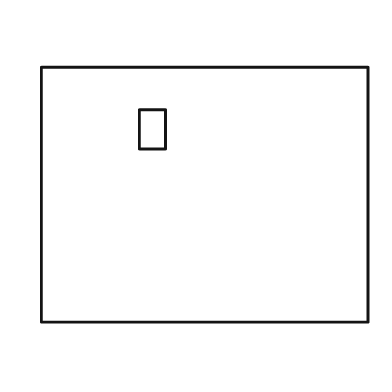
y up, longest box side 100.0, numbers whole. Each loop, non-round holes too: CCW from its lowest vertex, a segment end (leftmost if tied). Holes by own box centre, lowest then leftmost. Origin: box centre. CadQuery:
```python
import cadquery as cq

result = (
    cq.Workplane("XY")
    .moveTo(-50.0, -39.0)
    .lineTo(50.0, -39.0)
    .lineTo(50.0, 39.0)
    .lineTo(-50.0, 39.0)
    .close()
    .moveTo(-20.0, 14.0)
    .lineTo(-12.0, 14.0)
    .lineTo(-12.0, 26.0)
    .lineTo(-20.0, 26.0)
    .close()
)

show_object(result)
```